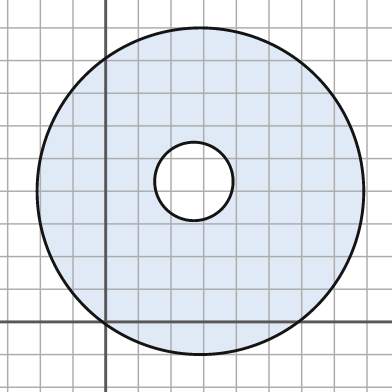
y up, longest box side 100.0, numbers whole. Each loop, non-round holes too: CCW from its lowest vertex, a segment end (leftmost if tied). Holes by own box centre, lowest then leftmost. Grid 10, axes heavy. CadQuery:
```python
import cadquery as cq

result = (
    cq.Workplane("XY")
    .moveTo(29.0, 40.0)
    .circle(50.0)
    .moveTo(27.0, 43.0)
    .circle(12.0)
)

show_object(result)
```